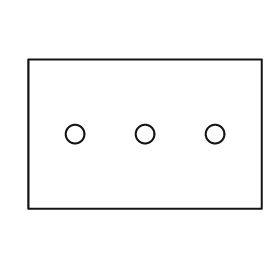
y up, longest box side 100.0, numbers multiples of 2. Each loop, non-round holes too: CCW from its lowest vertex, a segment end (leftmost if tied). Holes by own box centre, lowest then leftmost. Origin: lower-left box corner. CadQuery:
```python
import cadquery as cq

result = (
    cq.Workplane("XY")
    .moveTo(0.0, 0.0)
    .lineTo(100.0, 0.0)
    .lineTo(100.0, 64.0)
    .lineTo(0.0, 64.0)
    .close()
    .moveTo(20.0, 32.0)
    .circle(4.0)
    .moveTo(50.0, 32.0)
    .circle(4.0)
    .moveTo(80.0, 32.0)
    .circle(4.0)
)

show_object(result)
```